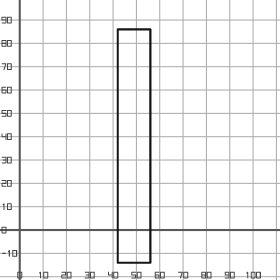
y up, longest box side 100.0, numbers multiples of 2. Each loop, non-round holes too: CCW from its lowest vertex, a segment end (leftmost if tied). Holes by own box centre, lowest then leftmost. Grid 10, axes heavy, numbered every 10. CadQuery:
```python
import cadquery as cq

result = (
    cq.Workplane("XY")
    .moveTo(42.0, -14.0)
    .lineTo(56.0, -14.0)
    .lineTo(56.0, 86.0)
    .lineTo(42.0, 86.0)
    .close()
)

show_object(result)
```